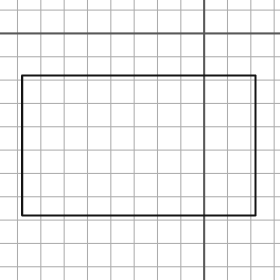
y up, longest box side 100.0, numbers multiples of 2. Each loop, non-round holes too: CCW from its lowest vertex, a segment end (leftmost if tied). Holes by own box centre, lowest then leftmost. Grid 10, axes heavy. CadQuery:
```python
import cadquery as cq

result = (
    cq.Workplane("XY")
    .moveTo(-78.0, -78.0)
    .lineTo(22.0, -78.0)
    .lineTo(22.0, -18.0)
    .lineTo(-78.0, -18.0)
    .close()
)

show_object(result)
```